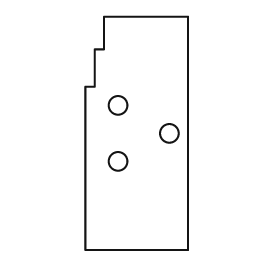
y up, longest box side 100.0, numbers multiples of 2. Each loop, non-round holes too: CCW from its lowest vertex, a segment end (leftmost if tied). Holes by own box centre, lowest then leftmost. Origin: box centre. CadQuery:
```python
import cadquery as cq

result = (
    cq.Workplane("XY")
    .moveTo(-22.0, -50.0)
    .lineTo(22.0, -50.0)
    .lineTo(22.0, 50.0)
    .lineTo(-14.0, 50.0)
    .lineTo(-14.0, 36.0)
    .lineTo(-18.0, 36.0)
    .lineTo(-18.0, 20.0)
    .lineTo(-22.0, 20.0)
    .close()
    .moveTo(-8.0, -12.0)
    .circle(4.0)
    .moveTo(14.0, 0.0)
    .circle(4.0)
    .moveTo(-8.0, 12.0)
    .circle(4.0)
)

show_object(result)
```